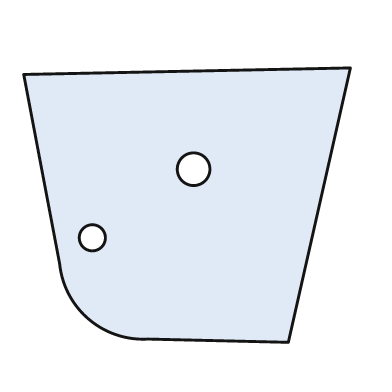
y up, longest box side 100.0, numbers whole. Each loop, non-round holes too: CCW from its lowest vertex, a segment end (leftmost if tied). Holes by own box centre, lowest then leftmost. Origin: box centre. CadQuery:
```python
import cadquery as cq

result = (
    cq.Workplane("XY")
    .moveTo(31.0, -42.0)
    .lineTo(50.0, 42.0)
    .lineTo(-50.0, 40.0)
    .lineTo(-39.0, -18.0)
    .threePointArc((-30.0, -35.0), (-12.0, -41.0))
    .close()
    .moveTo(-29.0, -10.0)
    .circle(4.0)
    .moveTo(2.0, 11.0)
    .circle(5.0)
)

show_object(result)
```